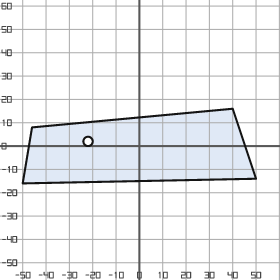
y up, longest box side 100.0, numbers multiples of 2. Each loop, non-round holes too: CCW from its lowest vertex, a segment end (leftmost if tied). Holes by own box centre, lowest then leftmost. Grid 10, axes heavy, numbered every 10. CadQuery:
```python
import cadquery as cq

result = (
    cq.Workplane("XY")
    .moveTo(-50.0, -16.0)
    .lineTo(50.0, -14.0)
    .lineTo(40.0, 16.0)
    .lineTo(-46.0, 8.0)
    .close()
    .moveTo(-22.0, 2.0)
    .circle(2.0)
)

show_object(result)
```